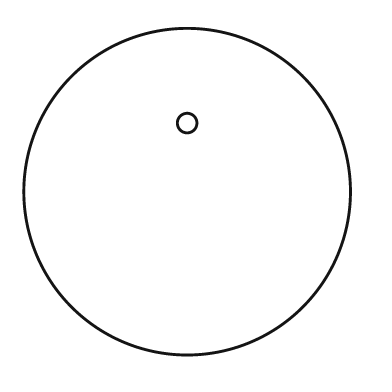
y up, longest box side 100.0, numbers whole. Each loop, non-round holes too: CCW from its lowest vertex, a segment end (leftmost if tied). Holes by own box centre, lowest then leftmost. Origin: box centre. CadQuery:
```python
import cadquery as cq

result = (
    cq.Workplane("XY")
    .moveTo(0.0, 0.0)
    .circle(50.0)
    .moveTo(0.0, 21.0)
    .circle(3.0)
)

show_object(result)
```